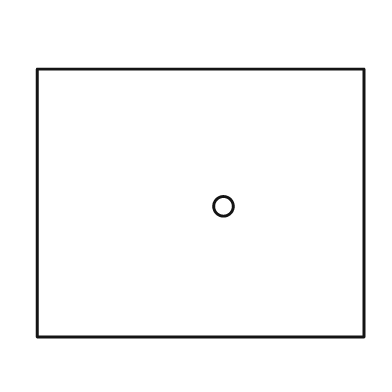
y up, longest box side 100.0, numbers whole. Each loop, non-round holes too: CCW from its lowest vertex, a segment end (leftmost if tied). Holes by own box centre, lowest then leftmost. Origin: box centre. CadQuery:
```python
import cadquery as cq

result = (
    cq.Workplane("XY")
    .moveTo(-50.0, -41.0)
    .lineTo(50.0, -41.0)
    .lineTo(50.0, 41.0)
    .lineTo(-50.0, 41.0)
    .close()
    .moveTo(7.0, -1.0)
    .circle(3.0)
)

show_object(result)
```